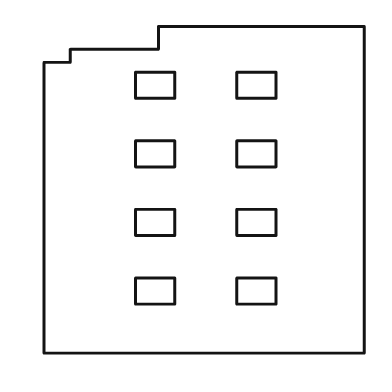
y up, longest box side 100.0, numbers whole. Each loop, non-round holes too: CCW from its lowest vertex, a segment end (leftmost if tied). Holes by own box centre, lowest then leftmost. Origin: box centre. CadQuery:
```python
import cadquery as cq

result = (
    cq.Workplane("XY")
    .moveTo(-49.0, -50.0)
    .lineTo(49.0, -50.0)
    .lineTo(49.0, 50.0)
    .lineTo(-14.0, 50.0)
    .lineTo(-14.0, 43.0)
    .lineTo(-41.0, 43.0)
    .lineTo(-41.0, 39.0)
    .lineTo(-49.0, 39.0)
    .close()
    .moveTo(-21.0, -35.0)
    .lineTo(-9.0, -35.0)
    .lineTo(-9.0, -27.0)
    .lineTo(-21.0, -27.0)
    .close()
    .moveTo(10.0, -35.0)
    .lineTo(22.0, -35.0)
    .lineTo(22.0, -27.0)
    .lineTo(10.0, -27.0)
    .close()
    .moveTo(-21.0, -14.0)
    .lineTo(-9.0, -14.0)
    .lineTo(-9.0, -6.0)
    .lineTo(-21.0, -6.0)
    .close()
    .moveTo(10.0, -14.0)
    .lineTo(22.0, -14.0)
    .lineTo(22.0, -6.0)
    .lineTo(10.0, -6.0)
    .close()
    .moveTo(-21.0, 7.0)
    .lineTo(-9.0, 7.0)
    .lineTo(-9.0, 15.0)
    .lineTo(-21.0, 15.0)
    .close()
    .moveTo(10.0, 7.0)
    .lineTo(22.0, 7.0)
    .lineTo(22.0, 15.0)
    .lineTo(10.0, 15.0)
    .close()
    .moveTo(-21.0, 28.0)
    .lineTo(-9.0, 28.0)
    .lineTo(-9.0, 36.0)
    .lineTo(-21.0, 36.0)
    .close()
    .moveTo(10.0, 28.0)
    .lineTo(22.0, 28.0)
    .lineTo(22.0, 36.0)
    .lineTo(10.0, 36.0)
    .close()
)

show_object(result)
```